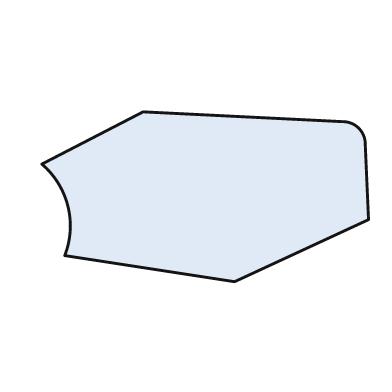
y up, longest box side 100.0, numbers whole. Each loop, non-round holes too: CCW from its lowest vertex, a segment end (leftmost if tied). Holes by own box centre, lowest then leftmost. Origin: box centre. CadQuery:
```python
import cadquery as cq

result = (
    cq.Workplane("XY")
    .moveTo(9.0, -26.0)
    .lineTo(50.0, -7.0)
    .lineTo(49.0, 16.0)
    .threePointArc((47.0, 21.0), (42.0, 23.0))
    .lineTo(-19.0, 26.0)
    .lineTo(-50.0, 10.0)
    .threePointArc((-42.0, -3.0), (-43.0, -18.0))
    .close()
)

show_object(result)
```